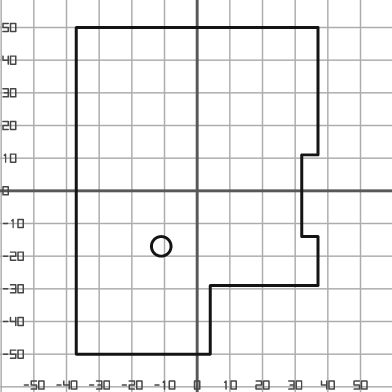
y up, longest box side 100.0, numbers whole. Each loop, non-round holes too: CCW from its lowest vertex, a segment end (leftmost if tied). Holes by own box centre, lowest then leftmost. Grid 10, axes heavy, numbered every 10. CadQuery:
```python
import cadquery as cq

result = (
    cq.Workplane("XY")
    .moveTo(-37.0, -50.0)
    .lineTo(4.0, -50.0)
    .lineTo(4.0, -29.0)
    .lineTo(37.0, -29.0)
    .lineTo(37.0, -14.0)
    .lineTo(32.0, -14.0)
    .lineTo(32.0, 11.0)
    .lineTo(37.0, 11.0)
    .lineTo(37.0, 50.0)
    .lineTo(-37.0, 50.0)
    .close()
    .moveTo(-11.0, -17.0)
    .circle(3.0)
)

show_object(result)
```